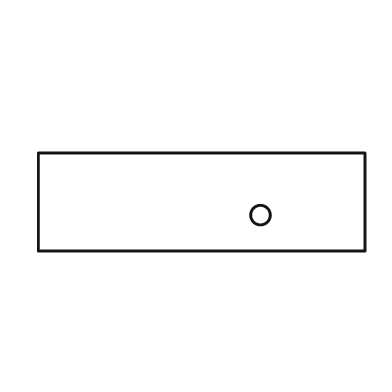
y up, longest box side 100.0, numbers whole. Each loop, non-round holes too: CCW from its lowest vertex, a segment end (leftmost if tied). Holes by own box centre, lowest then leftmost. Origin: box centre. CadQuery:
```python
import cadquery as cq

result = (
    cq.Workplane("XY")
    .moveTo(-50.0, -15.0)
    .lineTo(50.0, -15.0)
    .lineTo(50.0, 15.0)
    .lineTo(-50.0, 15.0)
    .close()
    .moveTo(18.0, -4.0)
    .circle(3.0)
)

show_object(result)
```